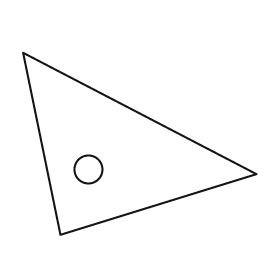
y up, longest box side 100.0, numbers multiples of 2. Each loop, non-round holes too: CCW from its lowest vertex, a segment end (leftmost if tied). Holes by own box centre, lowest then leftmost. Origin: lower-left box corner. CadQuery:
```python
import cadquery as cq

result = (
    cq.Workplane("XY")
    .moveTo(16.0, 0.0)
    .lineTo(100.0, 26.0)
    .lineTo(0.0, 78.0)
    .close()
    .moveTo(28.0, 28.0)
    .circle(6.0)
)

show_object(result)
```